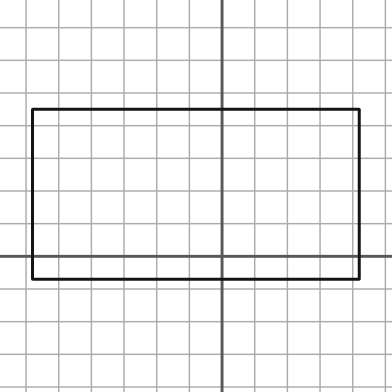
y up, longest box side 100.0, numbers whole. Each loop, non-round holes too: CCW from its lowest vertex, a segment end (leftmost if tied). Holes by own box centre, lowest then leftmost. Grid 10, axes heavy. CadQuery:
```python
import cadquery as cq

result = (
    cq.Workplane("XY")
    .moveTo(-58.0, -7.0)
    .lineTo(42.0, -7.0)
    .lineTo(42.0, 45.0)
    .lineTo(-58.0, 45.0)
    .close()
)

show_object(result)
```